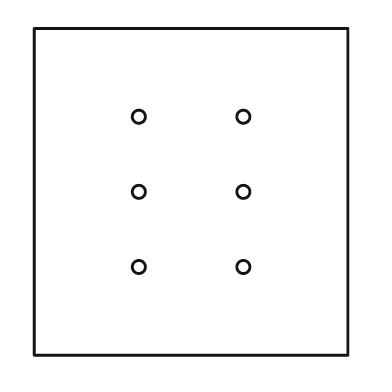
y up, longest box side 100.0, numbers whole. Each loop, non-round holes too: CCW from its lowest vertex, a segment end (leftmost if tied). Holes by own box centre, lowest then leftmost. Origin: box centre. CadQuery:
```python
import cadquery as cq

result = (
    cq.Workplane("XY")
    .moveTo(-48.0, -50.0)
    .lineTo(48.0, -50.0)
    .lineTo(48.0, 50.0)
    .lineTo(-48.0, 50.0)
    .close()
    .moveTo(-16.0, -23.0)
    .circle(2.0)
    .moveTo(16.0, -23.0)
    .circle(2.0)
    .moveTo(-16.0, 0.0)
    .circle(2.0)
    .moveTo(16.0, 0.0)
    .circle(2.0)
    .moveTo(-16.0, 23.0)
    .circle(2.0)
    .moveTo(16.0, 23.0)
    .circle(2.0)
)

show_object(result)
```